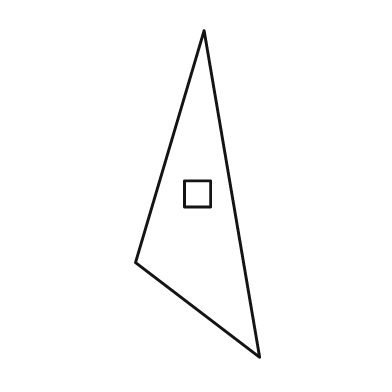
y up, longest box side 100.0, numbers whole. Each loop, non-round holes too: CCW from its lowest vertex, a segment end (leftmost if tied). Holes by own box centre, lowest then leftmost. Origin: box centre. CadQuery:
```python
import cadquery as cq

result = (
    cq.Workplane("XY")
    .moveTo(19.0, -50.0)
    .lineTo(2.0, 50.0)
    .lineTo(-19.0, -21.0)
    .close()
    .moveTo(-4.0, -4.0)
    .lineTo(4.0, -4.0)
    .lineTo(4.0, 4.0)
    .lineTo(-4.0, 4.0)
    .close()
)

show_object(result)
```